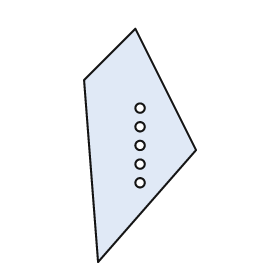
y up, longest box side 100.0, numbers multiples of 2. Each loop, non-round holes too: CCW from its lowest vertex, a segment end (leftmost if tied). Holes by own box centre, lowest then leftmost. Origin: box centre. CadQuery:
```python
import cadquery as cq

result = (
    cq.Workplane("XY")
    .moveTo(-18.0, -50.0)
    .lineTo(24.0, -2.0)
    .lineTo(-2.0, 50.0)
    .lineTo(-24.0, 28.0)
    .close()
    .moveTo(0.0, -16.0)
    .circle(2.0)
    .moveTo(0.0, -8.0)
    .circle(2.0)
    .moveTo(0.0, 0.0)
    .circle(2.0)
    .moveTo(0.0, 8.0)
    .circle(2.0)
    .moveTo(0.0, 16.0)
    .circle(2.0)
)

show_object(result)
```